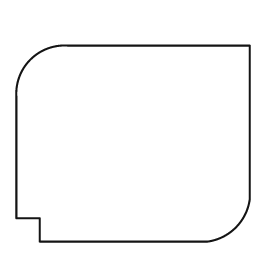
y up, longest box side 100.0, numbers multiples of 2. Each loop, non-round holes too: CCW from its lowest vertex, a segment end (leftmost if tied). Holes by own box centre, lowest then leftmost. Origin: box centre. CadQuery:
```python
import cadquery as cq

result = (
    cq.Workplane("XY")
    .moveTo(-40.0, -42.0)
    .lineTo(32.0, -42.0)
    .threePointArc((44.0, -36.0), (50.0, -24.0))
    .lineTo(50.0, 42.0)
    .lineTo(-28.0, 42.0)
    .threePointArc((-44.0, 36.0), (-50.0, 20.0))
    .lineTo(-50.0, -32.0)
    .lineTo(-40.0, -32.0)
    .close()
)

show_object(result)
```